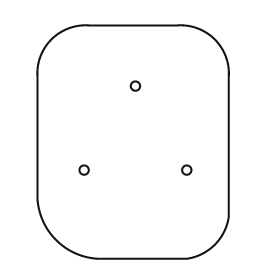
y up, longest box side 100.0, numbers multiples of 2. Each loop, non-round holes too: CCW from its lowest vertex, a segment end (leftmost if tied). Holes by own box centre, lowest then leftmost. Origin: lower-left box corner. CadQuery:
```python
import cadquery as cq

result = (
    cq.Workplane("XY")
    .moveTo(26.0, 0.0)
    .lineTo(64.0, 0.0)
    .threePointArc((76.0, 6.0), (82.0, 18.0))
    .lineTo(82.0, 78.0)
    .threePointArc((76.0, 94.0), (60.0, 100.0))
    .lineTo(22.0, 100.0)
    .threePointArc((6.0, 94.0), (0.0, 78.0))
    .lineTo(0.0, 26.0)
    .threePointArc((8.0, 8.0), (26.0, 0.0))
    .close()
    .moveTo(20.0, 38.0)
    .circle(2.0)
    .moveTo(64.0, 38.0)
    .circle(2.0)
    .moveTo(42.0, 74.0)
    .circle(2.0)
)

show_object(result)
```